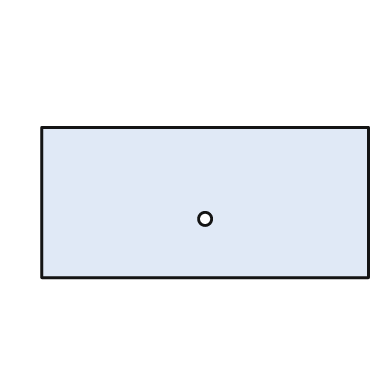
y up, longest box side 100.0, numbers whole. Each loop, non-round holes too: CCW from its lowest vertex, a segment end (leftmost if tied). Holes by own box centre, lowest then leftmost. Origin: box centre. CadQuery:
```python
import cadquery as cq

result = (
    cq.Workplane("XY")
    .moveTo(-50.0, -23.0)
    .lineTo(50.0, -23.0)
    .lineTo(50.0, 23.0)
    .lineTo(-50.0, 23.0)
    .close()
    .moveTo(0.0, -5.0)
    .circle(2.0)
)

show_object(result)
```